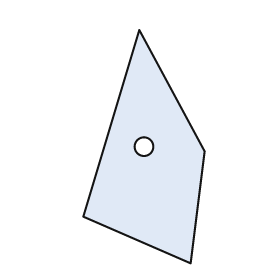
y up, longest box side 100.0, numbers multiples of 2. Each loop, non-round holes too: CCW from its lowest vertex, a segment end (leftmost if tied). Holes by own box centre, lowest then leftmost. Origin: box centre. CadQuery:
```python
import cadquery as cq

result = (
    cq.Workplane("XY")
    .moveTo(20.0, -50.0)
    .lineTo(26.0, -2.0)
    .lineTo(-2.0, 50.0)
    .lineTo(-26.0, -30.0)
    .close()
    .moveTo(0.0, 0.0)
    .circle(4.0)
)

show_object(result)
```